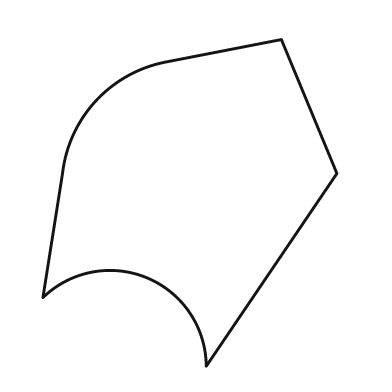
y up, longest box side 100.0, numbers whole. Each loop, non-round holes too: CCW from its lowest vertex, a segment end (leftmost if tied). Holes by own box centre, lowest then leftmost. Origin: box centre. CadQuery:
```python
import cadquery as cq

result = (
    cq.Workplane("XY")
    .moveTo(5.0, -50.0)
    .lineTo(45.0, 9.0)
    .lineTo(28.0, 50.0)
    .lineTo(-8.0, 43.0)
    .threePointArc((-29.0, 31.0), (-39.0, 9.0))
    .lineTo(-45.0, -29.0)
    .threePointArc((-13.0, -23.0), (5.0, -50.0))
    .close()
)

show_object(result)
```